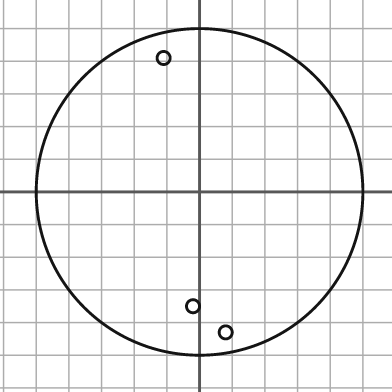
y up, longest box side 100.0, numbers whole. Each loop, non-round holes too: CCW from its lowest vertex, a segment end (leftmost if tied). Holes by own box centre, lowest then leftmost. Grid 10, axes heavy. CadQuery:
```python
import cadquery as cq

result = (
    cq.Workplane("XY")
    .moveTo(0.0, 0.0)
    .circle(50.0)
    .moveTo(8.0, -43.0)
    .circle(2.0)
    .moveTo(-2.0, -35.0)
    .circle(2.0)
    .moveTo(-11.0, 41.0)
    .circle(2.0)
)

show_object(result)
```